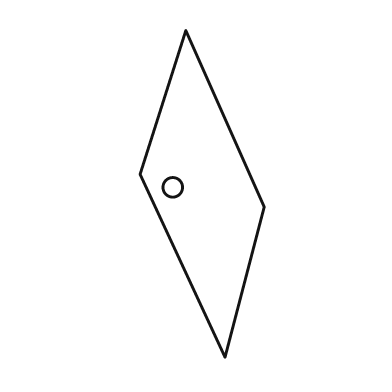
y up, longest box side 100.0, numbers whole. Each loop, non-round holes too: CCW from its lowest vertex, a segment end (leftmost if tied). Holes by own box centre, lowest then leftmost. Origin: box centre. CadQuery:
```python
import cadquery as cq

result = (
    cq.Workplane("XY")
    .moveTo(7.0, -50.0)
    .lineTo(19.0, -4.0)
    .lineTo(-5.0, 50.0)
    .lineTo(-19.0, 6.0)
    .close()
    .moveTo(-9.0, 2.0)
    .circle(3.0)
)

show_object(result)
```